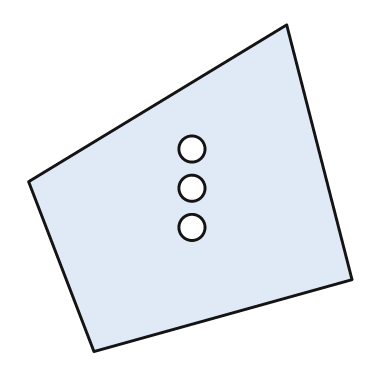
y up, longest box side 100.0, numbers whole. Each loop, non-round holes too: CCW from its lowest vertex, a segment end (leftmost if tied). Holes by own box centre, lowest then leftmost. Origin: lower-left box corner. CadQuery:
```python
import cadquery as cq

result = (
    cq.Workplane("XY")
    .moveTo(20.0, 0.0)
    .lineTo(99.0, 22.0)
    .lineTo(79.0, 100.0)
    .lineTo(0.0, 52.0)
    .close()
    .moveTo(50.0, 38.0)
    .circle(4.0)
    .moveTo(50.0, 50.0)
    .circle(4.0)
    .moveTo(50.0, 62.0)
    .circle(4.0)
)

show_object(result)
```